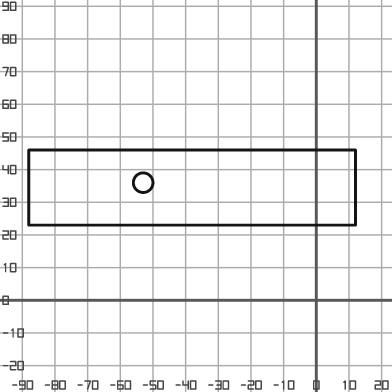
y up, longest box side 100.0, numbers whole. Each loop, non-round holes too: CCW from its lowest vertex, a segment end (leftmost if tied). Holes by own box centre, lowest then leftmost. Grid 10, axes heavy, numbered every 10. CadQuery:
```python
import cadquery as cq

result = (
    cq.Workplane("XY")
    .moveTo(-88.0, 23.0)
    .lineTo(12.0, 23.0)
    .lineTo(12.0, 46.0)
    .lineTo(-88.0, 46.0)
    .close()
    .moveTo(-53.0, 36.0)
    .circle(3.0)
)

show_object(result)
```